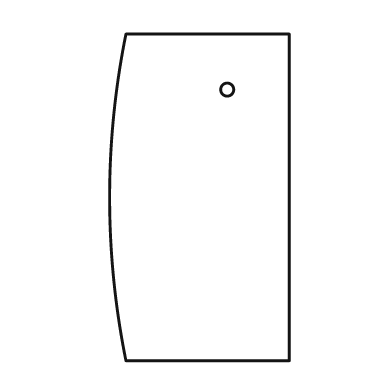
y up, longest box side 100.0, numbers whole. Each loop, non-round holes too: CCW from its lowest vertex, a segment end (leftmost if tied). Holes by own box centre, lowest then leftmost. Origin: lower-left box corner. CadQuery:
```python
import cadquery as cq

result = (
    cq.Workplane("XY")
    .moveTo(5.0, 0.0)
    .lineTo(55.0, 0.0)
    .lineTo(55.0, 100.0)
    .lineTo(5.0, 100.0)
    .threePointArc((0.0, 50.0), (5.0, 0.0))
    .close()
    .moveTo(36.0, 83.0)
    .circle(2.0)
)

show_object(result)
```